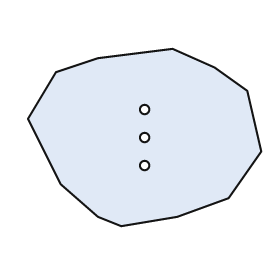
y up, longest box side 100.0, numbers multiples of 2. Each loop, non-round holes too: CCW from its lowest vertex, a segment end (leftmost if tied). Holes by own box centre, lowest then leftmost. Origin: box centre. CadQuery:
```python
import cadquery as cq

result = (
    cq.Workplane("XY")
    .moveTo(-10.0, -38.0)
    .lineTo(14.0, -34.0)
    .lineTo(36.0, -26.0)
    .lineTo(50.0, -6.0)
    .lineTo(44.0, 20.0)
    .lineTo(30.0, 30.0)
    .lineTo(12.0, 38.0)
    .lineTo(-20.0, 34.0)
    .lineTo(-38.0, 28.0)
    .lineTo(-50.0, 8.0)
    .lineTo(-36.0, -20.0)
    .lineTo(-20.0, -34.0)
    .close()
    .moveTo(0.0, -12.0)
    .circle(2.0)
    .moveTo(0.0, 0.0)
    .circle(2.0)
    .moveTo(0.0, 12.0)
    .circle(2.0)
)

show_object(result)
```